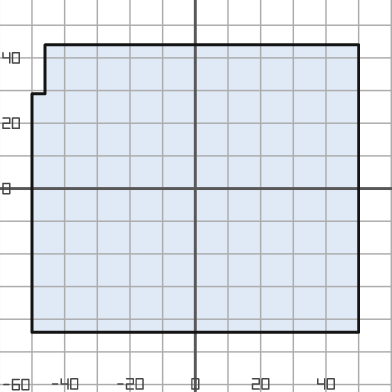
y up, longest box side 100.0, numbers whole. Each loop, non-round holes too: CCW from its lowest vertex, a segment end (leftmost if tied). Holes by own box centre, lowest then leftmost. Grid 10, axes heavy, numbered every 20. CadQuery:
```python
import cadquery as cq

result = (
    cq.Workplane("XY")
    .moveTo(-50.0, -44.0)
    .lineTo(50.0, -44.0)
    .lineTo(50.0, 44.0)
    .lineTo(-46.0, 44.0)
    .lineTo(-46.0, 29.0)
    .lineTo(-50.0, 29.0)
    .close()
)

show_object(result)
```